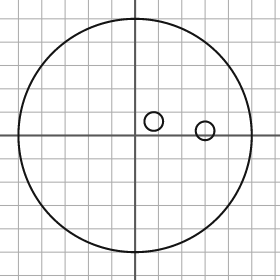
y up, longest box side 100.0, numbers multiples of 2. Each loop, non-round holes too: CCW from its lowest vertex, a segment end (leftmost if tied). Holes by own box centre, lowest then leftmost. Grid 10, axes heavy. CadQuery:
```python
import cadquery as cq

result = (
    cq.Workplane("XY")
    .moveTo(0.0, 0.0)
    .circle(50.0)
    .moveTo(30.0, 2.0)
    .circle(4.0)
    .moveTo(8.0, 6.0)
    .circle(4.0)
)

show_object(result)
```